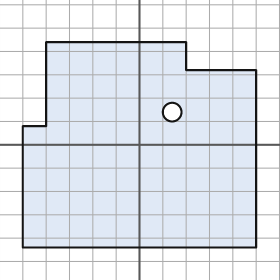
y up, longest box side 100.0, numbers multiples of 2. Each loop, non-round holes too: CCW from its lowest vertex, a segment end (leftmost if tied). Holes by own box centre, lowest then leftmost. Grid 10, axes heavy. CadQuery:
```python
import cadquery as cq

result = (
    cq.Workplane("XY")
    .moveTo(-50.0, -44.0)
    .lineTo(50.0, -44.0)
    .lineTo(50.0, 32.0)
    .lineTo(20.0, 32.0)
    .lineTo(20.0, 44.0)
    .lineTo(-40.0, 44.0)
    .lineTo(-40.0, 8.0)
    .lineTo(-50.0, 8.0)
    .close()
    .moveTo(14.0, 14.0)
    .circle(4.0)
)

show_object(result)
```